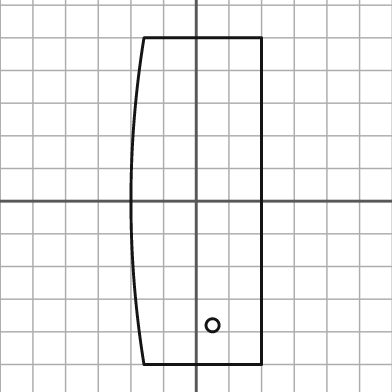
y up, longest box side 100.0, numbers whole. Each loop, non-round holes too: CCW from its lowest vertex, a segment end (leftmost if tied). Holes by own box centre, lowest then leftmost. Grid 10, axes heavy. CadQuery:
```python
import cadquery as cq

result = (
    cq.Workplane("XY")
    .moveTo(-16.0, -50.0)
    .lineTo(20.0, -50.0)
    .lineTo(20.0, 50.0)
    .lineTo(-16.0, 50.0)
    .threePointArc((-20.0, 0.0), (-16.0, -50.0))
    .close()
    .moveTo(5.0, -38.0)
    .circle(2.0)
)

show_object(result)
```